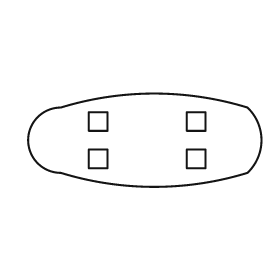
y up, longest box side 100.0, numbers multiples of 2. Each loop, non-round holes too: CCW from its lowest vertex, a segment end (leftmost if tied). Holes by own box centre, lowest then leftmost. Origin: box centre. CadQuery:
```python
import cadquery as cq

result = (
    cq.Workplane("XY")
    .moveTo(-36.0, -14.0)
    .threePointArc((4.0, -20.0), (44.0, -14.0))
    .threePointArc((50.0, 0.0), (44.0, 14.0))
    .threePointArc((4.0, 20.0), (-36.0, 14.0))
    .threePointArc((-50.0, 0.0), (-36.0, -14.0))
    .close()
    .moveTo(-24.0, -12.0)
    .lineTo(-16.0, -12.0)
    .lineTo(-16.0, -4.0)
    .lineTo(-24.0, -4.0)
    .close()
    .moveTo(18.0, -12.0)
    .lineTo(26.0, -12.0)
    .lineTo(26.0, -4.0)
    .lineTo(18.0, -4.0)
    .close()
    .moveTo(-24.0, 4.0)
    .lineTo(-16.0, 4.0)
    .lineTo(-16.0, 12.0)
    .lineTo(-24.0, 12.0)
    .close()
    .moveTo(18.0, 4.0)
    .lineTo(26.0, 4.0)
    .lineTo(26.0, 12.0)
    .lineTo(18.0, 12.0)
    .close()
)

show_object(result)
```